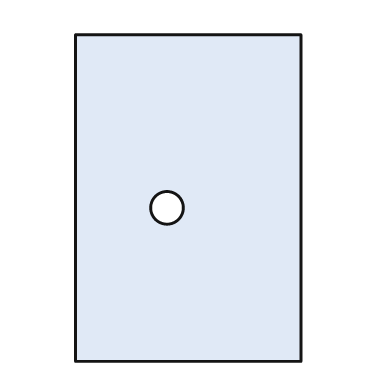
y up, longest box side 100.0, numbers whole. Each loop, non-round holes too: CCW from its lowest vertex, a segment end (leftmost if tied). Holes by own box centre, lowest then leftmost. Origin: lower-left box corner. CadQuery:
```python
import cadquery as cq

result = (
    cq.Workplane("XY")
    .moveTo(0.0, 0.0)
    .lineTo(69.0, 0.0)
    .lineTo(69.0, 100.0)
    .lineTo(0.0, 100.0)
    .close()
    .moveTo(28.0, 47.0)
    .circle(5.0)
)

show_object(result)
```